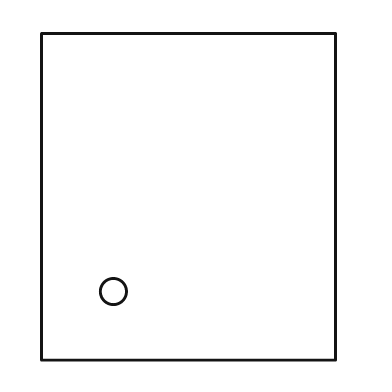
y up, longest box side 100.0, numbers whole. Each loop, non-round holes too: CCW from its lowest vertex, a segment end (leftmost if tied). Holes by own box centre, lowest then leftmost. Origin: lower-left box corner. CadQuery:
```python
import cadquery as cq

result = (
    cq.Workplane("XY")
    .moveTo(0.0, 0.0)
    .lineTo(90.0, 0.0)
    .lineTo(90.0, 100.0)
    .lineTo(0.0, 100.0)
    .close()
    .moveTo(22.0, 21.0)
    .circle(4.0)
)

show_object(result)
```